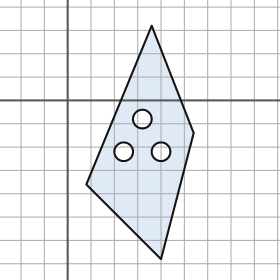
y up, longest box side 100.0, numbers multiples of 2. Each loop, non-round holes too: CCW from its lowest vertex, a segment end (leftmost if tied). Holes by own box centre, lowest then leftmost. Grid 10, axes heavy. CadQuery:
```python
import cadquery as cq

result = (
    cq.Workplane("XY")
    .moveTo(40.0, -68.0)
    .lineTo(54.0, -14.0)
    .lineTo(36.0, 32.0)
    .lineTo(8.0, -36.0)
    .close()
    .moveTo(24.0, -22.0)
    .circle(4.0)
    .moveTo(40.0, -22.0)
    .circle(4.0)
    .moveTo(32.0, -8.0)
    .circle(4.0)
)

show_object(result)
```